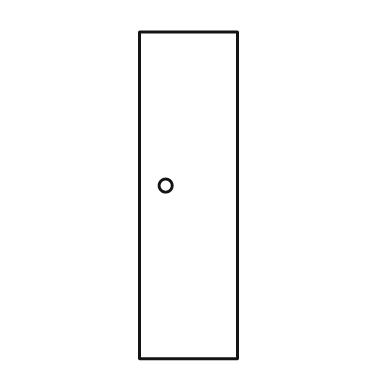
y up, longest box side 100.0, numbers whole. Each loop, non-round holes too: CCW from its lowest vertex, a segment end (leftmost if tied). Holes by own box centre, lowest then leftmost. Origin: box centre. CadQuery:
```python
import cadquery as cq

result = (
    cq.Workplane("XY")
    .moveTo(-15.0, -50.0)
    .lineTo(15.0, -50.0)
    .lineTo(15.0, 50.0)
    .lineTo(-15.0, 50.0)
    .close()
    .moveTo(-7.0, 3.0)
    .circle(2.0)
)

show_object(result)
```